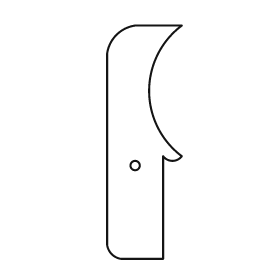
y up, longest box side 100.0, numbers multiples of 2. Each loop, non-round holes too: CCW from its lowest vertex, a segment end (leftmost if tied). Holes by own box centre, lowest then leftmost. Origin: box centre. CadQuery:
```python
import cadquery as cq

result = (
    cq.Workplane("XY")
    .moveTo(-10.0, -50.0)
    .lineTo(8.0, -50.0)
    .lineTo(8.0, -6.0)
    .threePointArc((12.0, -8.0), (16.0, -6.0))
    .threePointArc((2.0, 22.0), (16.0, 50.0))
    .lineTo(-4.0, 50.0)
    .threePointArc((-12.0, 46.0), (-16.0, 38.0))
    .lineTo(-16.0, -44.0)
    .threePointArc((-14.0, -48.0), (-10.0, -50.0))
    .close()
    .moveTo(-4.0, -10.0)
    .circle(2.0)
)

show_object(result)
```